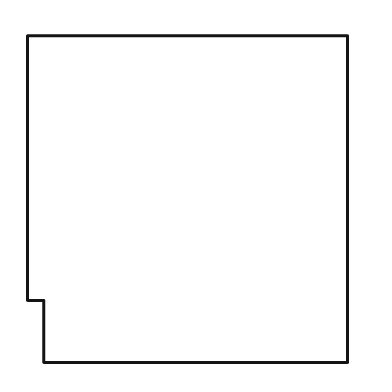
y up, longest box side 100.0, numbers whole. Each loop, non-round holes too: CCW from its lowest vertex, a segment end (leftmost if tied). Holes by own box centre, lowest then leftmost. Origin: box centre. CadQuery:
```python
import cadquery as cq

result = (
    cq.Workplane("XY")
    .moveTo(-44.0, -50.0)
    .lineTo(49.0, -50.0)
    .lineTo(49.0, 50.0)
    .lineTo(-49.0, 50.0)
    .lineTo(-49.0, -31.0)
    .lineTo(-44.0, -31.0)
    .close()
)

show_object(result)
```